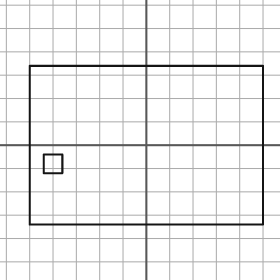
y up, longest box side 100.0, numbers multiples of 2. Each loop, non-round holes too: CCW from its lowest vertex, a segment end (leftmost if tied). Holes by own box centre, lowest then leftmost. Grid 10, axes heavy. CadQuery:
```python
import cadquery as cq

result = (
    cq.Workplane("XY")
    .moveTo(-50.0, -34.0)
    .lineTo(50.0, -34.0)
    .lineTo(50.0, 34.0)
    .lineTo(-50.0, 34.0)
    .close()
    .moveTo(-44.0, -12.0)
    .lineTo(-36.0, -12.0)
    .lineTo(-36.0, -4.0)
    .lineTo(-44.0, -4.0)
    .close()
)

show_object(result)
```